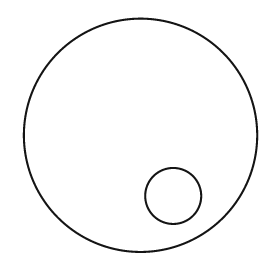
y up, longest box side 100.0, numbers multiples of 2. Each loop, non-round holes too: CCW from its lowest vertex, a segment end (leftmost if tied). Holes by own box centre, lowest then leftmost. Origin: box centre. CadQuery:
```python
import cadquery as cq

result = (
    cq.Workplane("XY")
    .moveTo(0.0, 0.0)
    .circle(50.0)
    .moveTo(14.0, -26.0)
    .circle(12.0)
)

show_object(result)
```